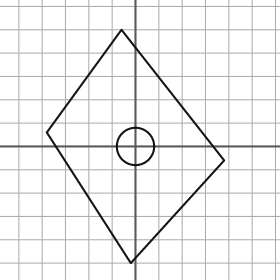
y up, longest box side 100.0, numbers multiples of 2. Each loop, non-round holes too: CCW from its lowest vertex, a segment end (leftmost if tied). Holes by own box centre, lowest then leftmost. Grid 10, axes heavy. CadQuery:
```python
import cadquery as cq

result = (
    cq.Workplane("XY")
    .moveTo(-2.0, -50.0)
    .lineTo(38.0, -6.0)
    .lineTo(-6.0, 50.0)
    .lineTo(-38.0, 6.0)
    .close()
    .moveTo(0.0, 0.0)
    .circle(8.0)
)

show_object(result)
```